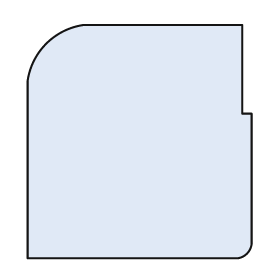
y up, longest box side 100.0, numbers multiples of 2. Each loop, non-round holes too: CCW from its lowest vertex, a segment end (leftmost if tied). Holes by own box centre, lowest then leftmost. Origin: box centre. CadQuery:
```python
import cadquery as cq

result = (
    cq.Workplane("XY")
    .moveTo(-48.0, -50.0)
    .lineTo(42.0, -50.0)
    .threePointArc((46.0, -48.0), (48.0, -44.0))
    .lineTo(48.0, 12.0)
    .lineTo(44.0, 12.0)
    .lineTo(44.0, 50.0)
    .lineTo(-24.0, 50.0)
    .threePointArc((-40.0, 42.0), (-48.0, 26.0))
    .close()
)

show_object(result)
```